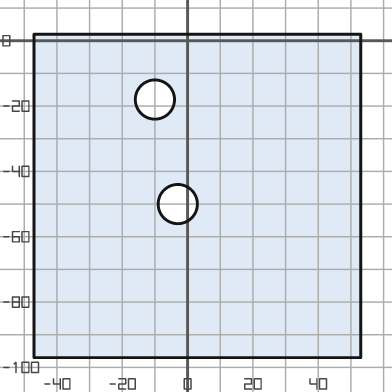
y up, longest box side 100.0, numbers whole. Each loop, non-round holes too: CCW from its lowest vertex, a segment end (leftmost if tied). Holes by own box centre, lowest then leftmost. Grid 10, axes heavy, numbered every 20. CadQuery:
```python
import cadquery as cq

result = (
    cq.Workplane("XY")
    .moveTo(-47.0, -97.0)
    .lineTo(53.0, -97.0)
    .lineTo(53.0, 2.0)
    .lineTo(-47.0, 2.0)
    .close()
    .moveTo(-3.0, -50.0)
    .circle(6.0)
    .moveTo(-10.0, -18.0)
    .circle(6.0)
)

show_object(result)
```